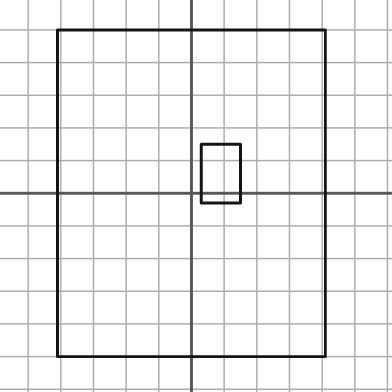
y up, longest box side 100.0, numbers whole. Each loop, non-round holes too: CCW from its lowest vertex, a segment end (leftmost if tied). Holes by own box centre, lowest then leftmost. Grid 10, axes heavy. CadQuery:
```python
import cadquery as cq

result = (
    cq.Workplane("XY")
    .moveTo(-41.0, -50.0)
    .lineTo(41.0, -50.0)
    .lineTo(41.0, 50.0)
    .lineTo(-41.0, 50.0)
    .close()
    .moveTo(3.0, -3.0)
    .lineTo(15.0, -3.0)
    .lineTo(15.0, 15.0)
    .lineTo(3.0, 15.0)
    .close()
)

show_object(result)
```